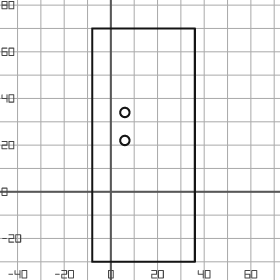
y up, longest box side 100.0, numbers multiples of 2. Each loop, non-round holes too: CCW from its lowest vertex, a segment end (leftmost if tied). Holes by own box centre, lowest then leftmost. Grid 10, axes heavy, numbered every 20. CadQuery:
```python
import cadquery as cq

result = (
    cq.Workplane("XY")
    .moveTo(-8.0, -30.0)
    .lineTo(36.0, -30.0)
    .lineTo(36.0, 70.0)
    .lineTo(-8.0, 70.0)
    .close()
    .moveTo(6.0, 22.0)
    .circle(2.0)
    .moveTo(6.0, 34.0)
    .circle(2.0)
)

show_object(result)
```